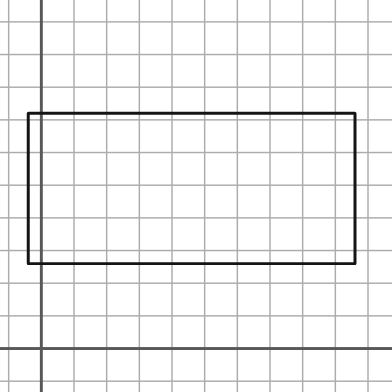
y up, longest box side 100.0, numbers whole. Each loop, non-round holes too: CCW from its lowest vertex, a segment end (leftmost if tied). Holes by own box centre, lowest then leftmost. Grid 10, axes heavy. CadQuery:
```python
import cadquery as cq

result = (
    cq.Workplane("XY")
    .moveTo(-4.0, 26.0)
    .lineTo(96.0, 26.0)
    .lineTo(96.0, 72.0)
    .lineTo(-4.0, 72.0)
    .close()
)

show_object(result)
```